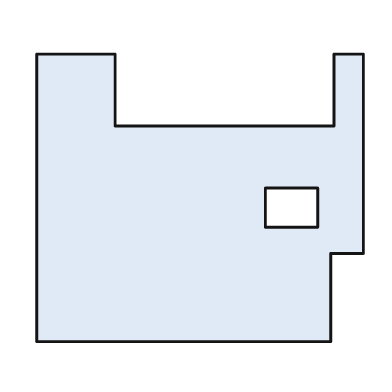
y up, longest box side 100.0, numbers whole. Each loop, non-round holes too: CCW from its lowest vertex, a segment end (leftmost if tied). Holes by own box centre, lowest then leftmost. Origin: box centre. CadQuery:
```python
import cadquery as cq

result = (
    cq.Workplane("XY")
    .moveTo(-50.0, -44.0)
    .lineTo(40.0, -44.0)
    .lineTo(40.0, -17.0)
    .lineTo(50.0, -17.0)
    .lineTo(50.0, 44.0)
    .lineTo(41.0, 44.0)
    .lineTo(41.0, 22.0)
    .lineTo(-26.0, 22.0)
    .lineTo(-26.0, 44.0)
    .lineTo(-50.0, 44.0)
    .close()
    .moveTo(20.0, -9.0)
    .lineTo(36.0, -9.0)
    .lineTo(36.0, 3.0)
    .lineTo(20.0, 3.0)
    .close()
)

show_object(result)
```